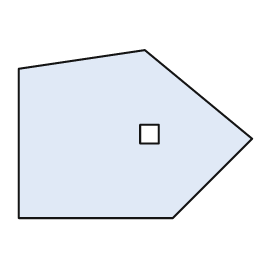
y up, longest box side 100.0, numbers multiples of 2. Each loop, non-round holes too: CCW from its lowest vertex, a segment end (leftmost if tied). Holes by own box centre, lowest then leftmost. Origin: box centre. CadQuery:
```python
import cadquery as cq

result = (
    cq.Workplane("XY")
    .moveTo(-50.0, -36.0)
    .lineTo(16.0, -36.0)
    .lineTo(50.0, -2.0)
    .lineTo(4.0, 36.0)
    .lineTo(-50.0, 28.0)
    .close()
    .moveTo(2.0, -4.0)
    .lineTo(10.0, -4.0)
    .lineTo(10.0, 4.0)
    .lineTo(2.0, 4.0)
    .close()
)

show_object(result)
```